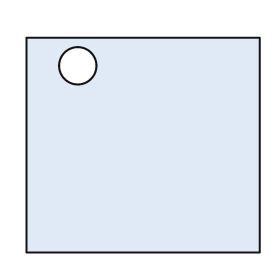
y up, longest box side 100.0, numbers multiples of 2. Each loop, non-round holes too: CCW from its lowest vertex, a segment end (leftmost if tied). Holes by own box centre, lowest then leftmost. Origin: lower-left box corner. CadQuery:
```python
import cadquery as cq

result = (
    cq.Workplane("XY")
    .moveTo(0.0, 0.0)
    .lineTo(100.0, 0.0)
    .lineTo(100.0, 92.0)
    .lineTo(0.0, 92.0)
    .close()
    .moveTo(22.0, 80.0)
    .circle(8.0)
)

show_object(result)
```